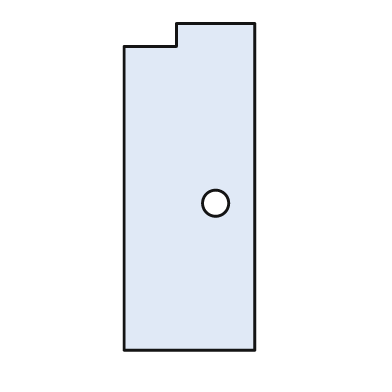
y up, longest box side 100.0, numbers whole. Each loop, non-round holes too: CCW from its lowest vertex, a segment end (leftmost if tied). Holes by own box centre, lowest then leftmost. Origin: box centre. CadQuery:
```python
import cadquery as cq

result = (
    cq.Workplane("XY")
    .moveTo(-20.0, -50.0)
    .lineTo(20.0, -50.0)
    .lineTo(20.0, 50.0)
    .lineTo(-4.0, 50.0)
    .lineTo(-4.0, 43.0)
    .lineTo(-20.0, 43.0)
    .close()
    .moveTo(8.0, -5.0)
    .circle(4.0)
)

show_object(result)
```